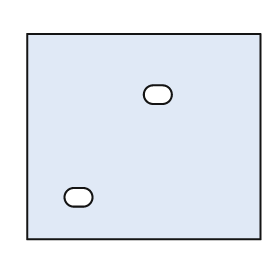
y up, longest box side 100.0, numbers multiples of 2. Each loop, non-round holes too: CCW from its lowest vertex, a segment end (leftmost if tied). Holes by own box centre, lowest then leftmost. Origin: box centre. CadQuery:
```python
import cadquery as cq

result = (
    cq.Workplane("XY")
    .moveTo(-50.0, -44.0)
    .lineTo(50.0, -44.0)
    .lineTo(50.0, 44.0)
    .lineTo(-50.0, 44.0)
    .close()
    .moveTo(-30.0, -30.0)
    .lineTo(-26.0, -30.0)
    .threePointArc((-22.0, -26.0), (-26.0, -22.0))
    .lineTo(-30.0, -22.0)
    .threePointArc((-34.0, -26.0), (-30.0, -30.0))
    .close()
    .moveTo(4.0, 14.0)
    .lineTo(8.0, 14.0)
    .threePointArc((12.0, 18.0), (8.0, 22.0))
    .lineTo(4.0, 22.0)
    .threePointArc((0.0, 18.0), (4.0, 14.0))
    .close()
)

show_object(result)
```